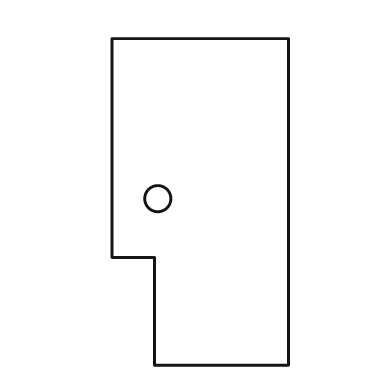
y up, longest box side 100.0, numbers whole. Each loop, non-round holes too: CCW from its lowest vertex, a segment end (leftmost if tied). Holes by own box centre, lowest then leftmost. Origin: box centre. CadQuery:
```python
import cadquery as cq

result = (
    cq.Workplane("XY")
    .moveTo(-14.0, -50.0)
    .lineTo(27.0, -50.0)
    .lineTo(27.0, 50.0)
    .lineTo(-27.0, 50.0)
    .lineTo(-27.0, -17.0)
    .lineTo(-14.0, -17.0)
    .close()
    .moveTo(-13.0, 1.0)
    .circle(4.0)
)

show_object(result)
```